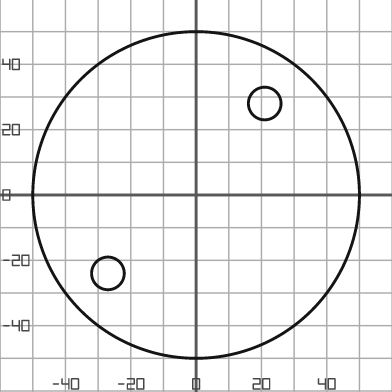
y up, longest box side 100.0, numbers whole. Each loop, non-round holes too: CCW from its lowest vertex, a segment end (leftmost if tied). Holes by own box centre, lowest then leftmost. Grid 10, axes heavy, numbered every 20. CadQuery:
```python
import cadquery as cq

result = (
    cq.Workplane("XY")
    .moveTo(0.0, 0.0)
    .circle(50.0)
    .moveTo(-27.0, -24.0)
    .circle(5.0)
    .moveTo(21.0, 28.0)
    .circle(5.0)
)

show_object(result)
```